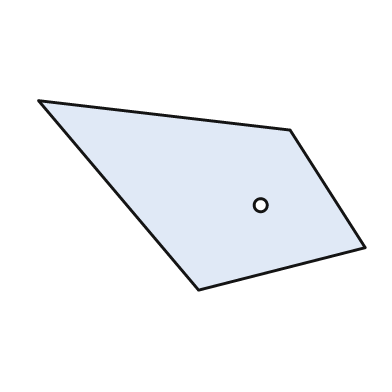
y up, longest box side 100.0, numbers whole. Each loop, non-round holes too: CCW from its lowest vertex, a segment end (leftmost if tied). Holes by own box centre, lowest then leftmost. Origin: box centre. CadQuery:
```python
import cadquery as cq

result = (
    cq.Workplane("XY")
    .moveTo(-1.0, -29.0)
    .lineTo(50.0, -16.0)
    .lineTo(27.0, 20.0)
    .lineTo(-50.0, 29.0)
    .close()
    .moveTo(18.0, -3.0)
    .circle(2.0)
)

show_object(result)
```